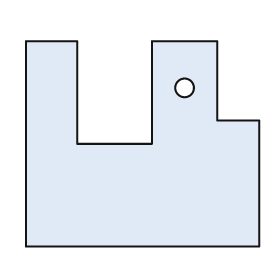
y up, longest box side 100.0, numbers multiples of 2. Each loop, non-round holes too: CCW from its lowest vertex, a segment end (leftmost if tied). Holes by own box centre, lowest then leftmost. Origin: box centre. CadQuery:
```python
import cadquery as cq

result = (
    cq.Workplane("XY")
    .moveTo(-50.0, -44.0)
    .lineTo(50.0, -44.0)
    .lineTo(50.0, 10.0)
    .lineTo(32.0, 10.0)
    .lineTo(32.0, 44.0)
    .lineTo(4.0, 44.0)
    .lineTo(4.0, 0.0)
    .lineTo(-28.0, 0.0)
    .lineTo(-28.0, 44.0)
    .lineTo(-50.0, 44.0)
    .close()
    .moveTo(18.0, 24.0)
    .circle(4.0)
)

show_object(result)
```